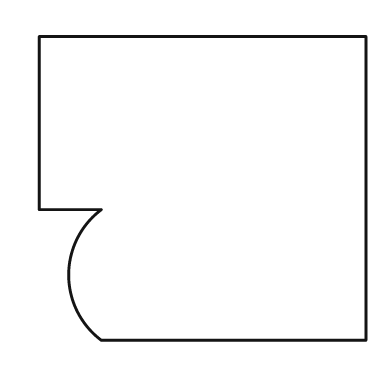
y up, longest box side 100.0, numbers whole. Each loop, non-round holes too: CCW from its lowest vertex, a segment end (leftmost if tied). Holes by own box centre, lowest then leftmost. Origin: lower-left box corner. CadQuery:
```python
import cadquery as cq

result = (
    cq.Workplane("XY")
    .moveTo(19.0, 0.0)
    .lineTo(100.0, 0.0)
    .lineTo(100.0, 93.0)
    .lineTo(0.0, 93.0)
    .lineTo(0.0, 40.0)
    .lineTo(19.0, 40.0)
    .threePointArc((9.0, 20.0), (19.0, 0.0))
    .close()
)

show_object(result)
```